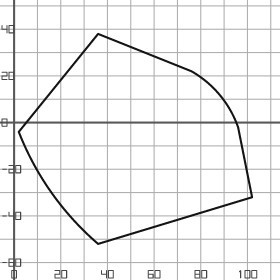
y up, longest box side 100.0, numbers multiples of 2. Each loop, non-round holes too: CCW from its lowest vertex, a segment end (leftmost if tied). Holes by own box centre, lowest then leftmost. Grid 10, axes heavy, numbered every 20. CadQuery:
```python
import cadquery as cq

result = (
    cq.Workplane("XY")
    .moveTo(36.0, -52.0)
    .lineTo(102.0, -32.0)
    .lineTo(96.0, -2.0)
    .threePointArc((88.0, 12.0), (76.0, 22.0))
    .lineTo(36.0, 38.0)
    .lineTo(2.0, -4.0)
    .threePointArc((16.0, -30.0), (36.0, -52.0))
    .close()
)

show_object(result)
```